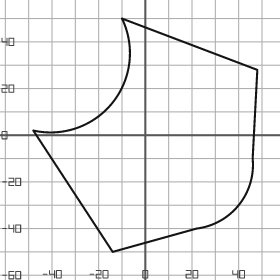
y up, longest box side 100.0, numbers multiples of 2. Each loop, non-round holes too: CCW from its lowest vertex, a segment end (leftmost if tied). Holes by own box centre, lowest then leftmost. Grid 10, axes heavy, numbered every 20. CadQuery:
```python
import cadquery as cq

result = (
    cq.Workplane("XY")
    .moveTo(-14.0, -50.0)
    .lineTo(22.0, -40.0)
    .threePointArc((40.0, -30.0), (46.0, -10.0))
    .lineTo(48.0, 28.0)
    .lineTo(-10.0, 50.0)
    .threePointArc((-14.0, 14.0), (-48.0, 2.0))
    .close()
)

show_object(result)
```